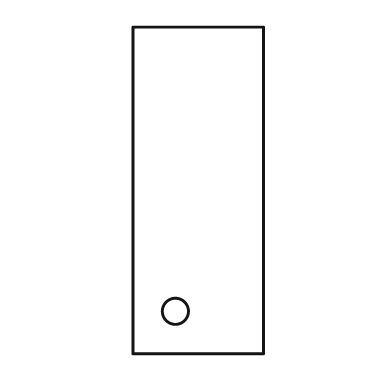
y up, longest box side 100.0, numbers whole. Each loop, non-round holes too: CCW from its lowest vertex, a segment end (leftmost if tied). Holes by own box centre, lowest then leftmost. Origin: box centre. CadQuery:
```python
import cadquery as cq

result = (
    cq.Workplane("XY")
    .moveTo(-20.0, -50.0)
    .lineTo(20.0, -50.0)
    .lineTo(20.0, 50.0)
    .lineTo(-20.0, 50.0)
    .close()
    .moveTo(-7.0, -37.0)
    .circle(4.0)
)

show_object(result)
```